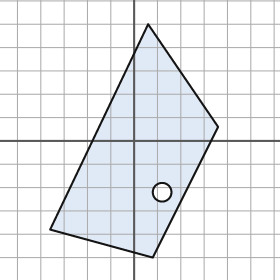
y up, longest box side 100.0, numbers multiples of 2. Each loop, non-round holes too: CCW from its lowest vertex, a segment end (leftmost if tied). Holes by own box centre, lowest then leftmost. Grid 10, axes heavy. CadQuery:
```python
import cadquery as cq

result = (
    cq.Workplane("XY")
    .moveTo(8.0, -50.0)
    .lineTo(36.0, 6.0)
    .lineTo(6.0, 50.0)
    .lineTo(-36.0, -38.0)
    .close()
    .moveTo(12.0, -22.0)
    .circle(4.0)
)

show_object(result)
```